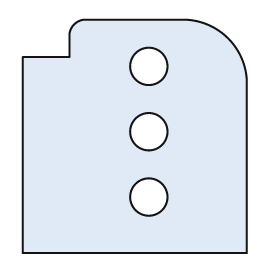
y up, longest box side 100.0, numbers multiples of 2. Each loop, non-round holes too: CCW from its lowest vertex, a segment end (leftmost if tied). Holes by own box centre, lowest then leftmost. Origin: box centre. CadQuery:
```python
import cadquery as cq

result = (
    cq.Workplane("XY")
    .moveTo(-48.0, -50.0)
    .lineTo(48.0, -50.0)
    .lineTo(48.0, 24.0)
    .threePointArc((40.0, 42.0), (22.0, 50.0))
    .lineTo(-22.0, 50.0)
    .threePointArc((-26.0, 48.0), (-28.0, 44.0))
    .lineTo(-28.0, 34.0)
    .lineTo(-48.0, 34.0)
    .close()
    .moveTo(6.0, -26.0)
    .circle(8.0)
    .moveTo(6.0, 2.0)
    .circle(8.0)
    .moveTo(6.0, 30.0)
    .circle(8.0)
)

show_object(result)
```